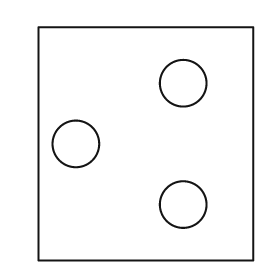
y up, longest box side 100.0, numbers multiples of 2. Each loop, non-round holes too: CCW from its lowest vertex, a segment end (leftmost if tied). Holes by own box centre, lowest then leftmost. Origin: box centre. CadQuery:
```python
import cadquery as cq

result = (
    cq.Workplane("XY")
    .moveTo(-46.0, -50.0)
    .lineTo(46.0, -50.0)
    .lineTo(46.0, 50.0)
    .lineTo(-46.0, 50.0)
    .close()
    .moveTo(16.0, -26.0)
    .circle(10.0)
    .moveTo(-30.0, 0.0)
    .circle(10.0)
    .moveTo(16.0, 26.0)
    .circle(10.0)
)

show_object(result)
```